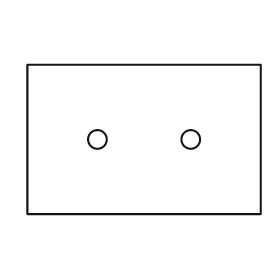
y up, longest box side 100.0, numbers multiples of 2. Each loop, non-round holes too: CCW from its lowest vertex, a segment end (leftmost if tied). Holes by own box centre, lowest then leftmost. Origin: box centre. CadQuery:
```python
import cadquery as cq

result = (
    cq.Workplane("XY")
    .moveTo(-50.0, -32.0)
    .lineTo(50.0, -32.0)
    .lineTo(50.0, 32.0)
    .lineTo(-50.0, 32.0)
    .close()
    .moveTo(-20.0, 0.0)
    .circle(4.0)
    .moveTo(20.0, 0.0)
    .circle(4.0)
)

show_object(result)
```